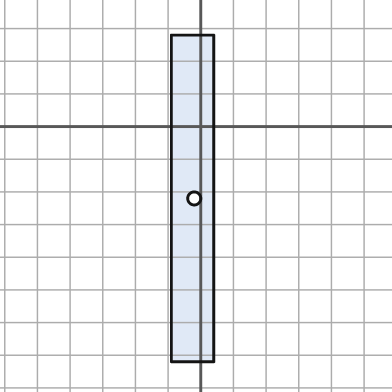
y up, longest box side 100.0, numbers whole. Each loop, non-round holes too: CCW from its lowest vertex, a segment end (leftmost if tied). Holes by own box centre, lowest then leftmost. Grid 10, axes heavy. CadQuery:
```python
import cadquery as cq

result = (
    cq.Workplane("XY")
    .moveTo(-9.0, -72.0)
    .lineTo(4.0, -72.0)
    .lineTo(4.0, 28.0)
    .lineTo(-9.0, 28.0)
    .close()
    .moveTo(-2.0, -22.0)
    .circle(2.0)
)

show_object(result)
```